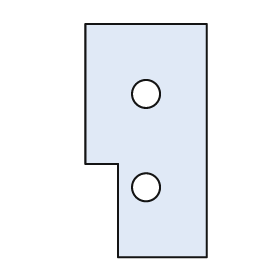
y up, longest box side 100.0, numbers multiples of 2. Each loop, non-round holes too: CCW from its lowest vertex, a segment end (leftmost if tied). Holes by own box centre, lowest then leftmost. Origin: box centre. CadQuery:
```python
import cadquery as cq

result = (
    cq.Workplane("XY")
    .moveTo(-12.0, -50.0)
    .lineTo(26.0, -50.0)
    .lineTo(26.0, 50.0)
    .lineTo(-26.0, 50.0)
    .lineTo(-26.0, -10.0)
    .lineTo(-12.0, -10.0)
    .close()
    .moveTo(0.0, -20.0)
    .circle(6.0)
    .moveTo(0.0, 20.0)
    .circle(6.0)
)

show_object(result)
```